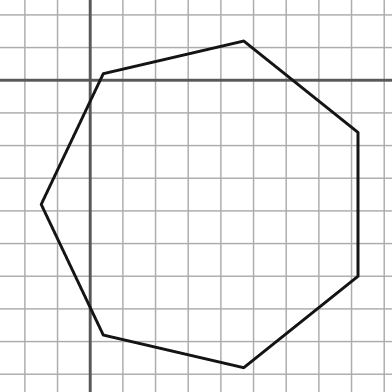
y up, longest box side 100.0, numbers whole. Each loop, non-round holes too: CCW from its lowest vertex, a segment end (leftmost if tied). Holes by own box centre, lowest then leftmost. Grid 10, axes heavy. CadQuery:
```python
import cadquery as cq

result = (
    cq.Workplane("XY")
    .moveTo(47.0, -88.0)
    .lineTo(82.0, -60.0)
    .lineTo(82.0, -16.0)
    .lineTo(47.0, 12.0)
    .lineTo(4.0, 2.0)
    .lineTo(-15.0, -38.0)
    .lineTo(4.0, -78.0)
    .close()
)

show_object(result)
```